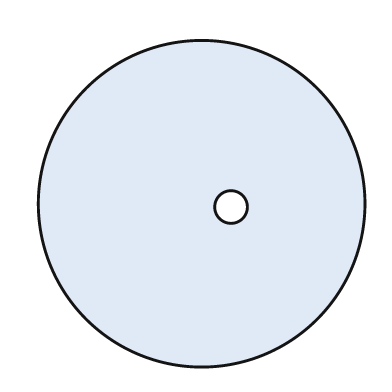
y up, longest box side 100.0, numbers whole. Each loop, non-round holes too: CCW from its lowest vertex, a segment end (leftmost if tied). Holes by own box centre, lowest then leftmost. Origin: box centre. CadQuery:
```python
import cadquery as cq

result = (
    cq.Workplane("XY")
    .moveTo(0.0, 0.0)
    .circle(50.0)
    .moveTo(9.0, -1.0)
    .circle(5.0)
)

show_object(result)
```